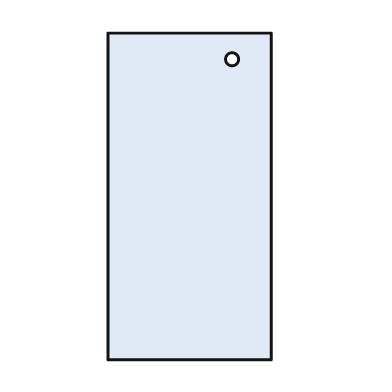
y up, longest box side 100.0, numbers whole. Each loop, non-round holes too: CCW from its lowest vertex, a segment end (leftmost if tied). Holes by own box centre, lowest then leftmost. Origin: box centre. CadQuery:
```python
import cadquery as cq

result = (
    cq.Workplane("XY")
    .moveTo(-25.0, -50.0)
    .lineTo(25.0, -50.0)
    .lineTo(25.0, 50.0)
    .lineTo(-25.0, 50.0)
    .close()
    .moveTo(13.0, 42.0)
    .circle(2.0)
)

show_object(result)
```